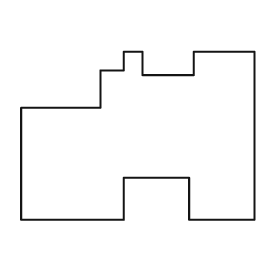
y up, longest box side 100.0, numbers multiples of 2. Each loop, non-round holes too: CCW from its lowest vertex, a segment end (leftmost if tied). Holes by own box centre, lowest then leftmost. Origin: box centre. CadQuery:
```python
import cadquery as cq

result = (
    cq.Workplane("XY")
    .moveTo(-50.0, -36.0)
    .lineTo(-6.0, -36.0)
    .lineTo(-6.0, -18.0)
    .lineTo(22.0, -18.0)
    .lineTo(22.0, -36.0)
    .lineTo(50.0, -36.0)
    .lineTo(50.0, 36.0)
    .lineTo(24.0, 36.0)
    .lineTo(24.0, 26.0)
    .lineTo(2.0, 26.0)
    .lineTo(2.0, 36.0)
    .lineTo(-6.0, 36.0)
    .lineTo(-6.0, 28.0)
    .lineTo(-16.0, 28.0)
    .lineTo(-16.0, 12.0)
    .lineTo(-50.0, 12.0)
    .close()
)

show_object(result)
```